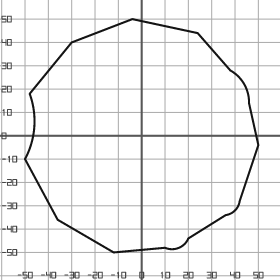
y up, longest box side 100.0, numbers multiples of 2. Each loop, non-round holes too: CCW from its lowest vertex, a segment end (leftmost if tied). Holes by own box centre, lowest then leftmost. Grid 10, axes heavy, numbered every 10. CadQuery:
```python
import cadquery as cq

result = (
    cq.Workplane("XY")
    .moveTo(-12.0, -50.0)
    .lineTo(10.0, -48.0)
    .threePointArc((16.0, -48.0), (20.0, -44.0))
    .lineTo(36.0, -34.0)
    .threePointArc((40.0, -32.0), (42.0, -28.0))
    .lineTo(50.0, -4.0)
    .lineTo(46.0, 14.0)
    .threePointArc((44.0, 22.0), (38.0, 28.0))
    .lineTo(24.0, 44.0)
    .lineTo(-4.0, 50.0)
    .lineTo(-30.0, 40.0)
    .lineTo(-48.0, 18.0)
    .threePointArc((-46.0, 4.0), (-50.0, -10.0))
    .lineTo(-36.0, -36.0)
    .close()
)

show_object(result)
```